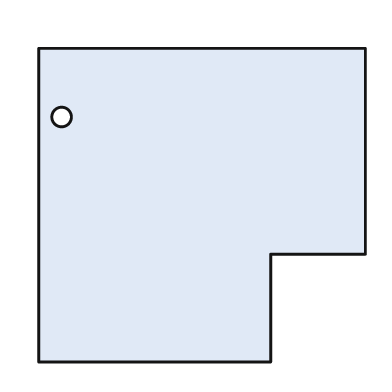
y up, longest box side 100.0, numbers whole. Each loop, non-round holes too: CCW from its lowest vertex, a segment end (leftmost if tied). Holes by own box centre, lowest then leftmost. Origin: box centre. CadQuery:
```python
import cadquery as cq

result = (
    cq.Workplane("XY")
    .moveTo(-50.0, -48.0)
    .lineTo(21.0, -48.0)
    .lineTo(21.0, -15.0)
    .lineTo(50.0, -15.0)
    .lineTo(50.0, 48.0)
    .lineTo(-50.0, 48.0)
    .close()
    .moveTo(-43.0, 27.0)
    .circle(3.0)
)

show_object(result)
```